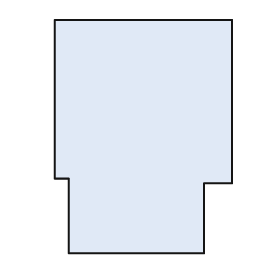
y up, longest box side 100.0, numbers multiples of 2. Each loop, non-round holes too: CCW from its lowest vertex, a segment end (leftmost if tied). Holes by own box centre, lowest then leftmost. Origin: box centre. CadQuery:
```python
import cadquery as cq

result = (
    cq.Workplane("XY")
    .moveTo(-32.0, -50.0)
    .lineTo(26.0, -50.0)
    .lineTo(26.0, -20.0)
    .lineTo(38.0, -20.0)
    .lineTo(38.0, 50.0)
    .lineTo(-38.0, 50.0)
    .lineTo(-38.0, -18.0)
    .lineTo(-32.0, -18.0)
    .close()
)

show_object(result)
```